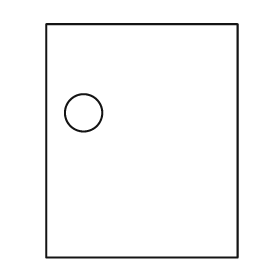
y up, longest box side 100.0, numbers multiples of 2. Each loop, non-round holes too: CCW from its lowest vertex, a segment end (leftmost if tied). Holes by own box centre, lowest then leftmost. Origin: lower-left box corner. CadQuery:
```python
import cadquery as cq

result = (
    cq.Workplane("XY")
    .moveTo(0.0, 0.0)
    .lineTo(82.0, 0.0)
    .lineTo(82.0, 100.0)
    .lineTo(0.0, 100.0)
    .close()
    .moveTo(16.0, 62.0)
    .circle(8.0)
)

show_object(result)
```